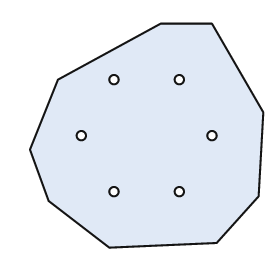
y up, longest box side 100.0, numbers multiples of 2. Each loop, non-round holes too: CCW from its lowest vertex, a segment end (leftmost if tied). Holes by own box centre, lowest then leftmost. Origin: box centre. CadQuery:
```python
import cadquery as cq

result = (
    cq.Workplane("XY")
    .moveTo(-16.0, -48.0)
    .lineTo(30.0, -46.0)
    .lineTo(48.0, -26.0)
    .lineTo(50.0, 10.0)
    .lineTo(28.0, 48.0)
    .lineTo(6.0, 48.0)
    .lineTo(-38.0, 24.0)
    .lineTo(-50.0, -6.0)
    .lineTo(-42.0, -28.0)
    .close()
    .moveTo(-14.0, -24.0)
    .circle(2.0)
    .moveTo(14.0, -24.0)
    .circle(2.0)
    .moveTo(-28.0, 0.0)
    .circle(2.0)
    .moveTo(28.0, 0.0)
    .circle(2.0)
    .moveTo(-14.0, 24.0)
    .circle(2.0)
    .moveTo(14.0, 24.0)
    .circle(2.0)
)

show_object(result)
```